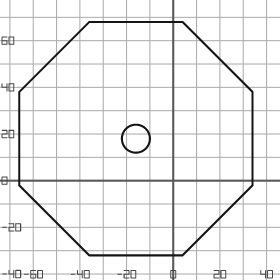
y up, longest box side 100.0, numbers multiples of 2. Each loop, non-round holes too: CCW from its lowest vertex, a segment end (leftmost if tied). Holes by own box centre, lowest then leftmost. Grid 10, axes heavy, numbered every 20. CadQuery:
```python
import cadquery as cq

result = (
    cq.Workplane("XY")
    .moveTo(-36.0, -32.0)
    .lineTo(4.0, -32.0)
    .lineTo(34.0, -2.0)
    .lineTo(34.0, 38.0)
    .lineTo(4.0, 68.0)
    .lineTo(-36.0, 68.0)
    .lineTo(-66.0, 38.0)
    .lineTo(-66.0, -2.0)
    .close()
    .moveTo(-16.0, 18.0)
    .circle(6.0)
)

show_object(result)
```